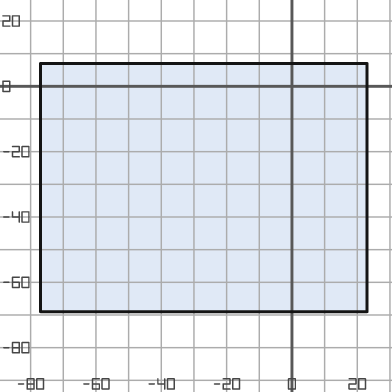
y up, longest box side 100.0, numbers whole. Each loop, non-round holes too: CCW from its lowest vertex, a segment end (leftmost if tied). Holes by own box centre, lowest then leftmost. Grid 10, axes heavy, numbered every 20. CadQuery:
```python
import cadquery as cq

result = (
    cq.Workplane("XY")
    .moveTo(-77.0, -69.0)
    .lineTo(23.0, -69.0)
    .lineTo(23.0, 7.0)
    .lineTo(-77.0, 7.0)
    .close()
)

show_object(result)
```